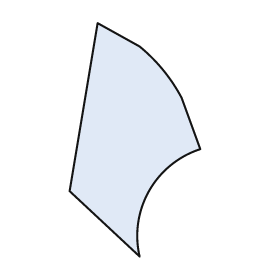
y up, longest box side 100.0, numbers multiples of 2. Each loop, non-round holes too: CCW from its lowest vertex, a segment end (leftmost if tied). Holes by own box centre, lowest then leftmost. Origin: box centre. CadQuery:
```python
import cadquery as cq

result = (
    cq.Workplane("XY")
    .moveTo(2.0, -50.0)
    .threePointArc((6.0, -22.0), (28.0, -4.0))
    .lineTo(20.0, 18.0)
    .threePointArc((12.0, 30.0), (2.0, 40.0))
    .lineTo(-16.0, 50.0)
    .lineTo(-28.0, -22.0)
    .close()
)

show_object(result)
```